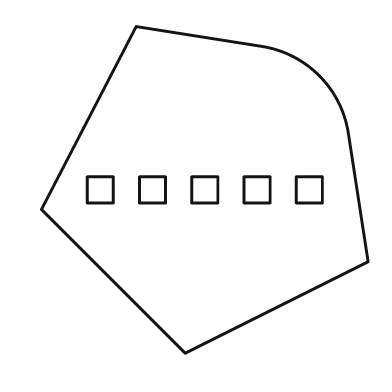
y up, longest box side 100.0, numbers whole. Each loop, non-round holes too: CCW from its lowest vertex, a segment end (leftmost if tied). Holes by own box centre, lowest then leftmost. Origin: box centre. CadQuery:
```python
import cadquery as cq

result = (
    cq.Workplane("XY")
    .moveTo(-6.0, -50.0)
    .lineTo(50.0, -22.0)
    .lineTo(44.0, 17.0)
    .threePointArc((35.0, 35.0), (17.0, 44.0))
    .lineTo(-21.0, 50.0)
    .lineTo(-50.0, -6.0)
    .close()
    .moveTo(-36.0, -4.0)
    .lineTo(-28.0, -4.0)
    .lineTo(-28.0, 4.0)
    .lineTo(-36.0, 4.0)
    .close()
    .moveTo(-20.0, -4.0)
    .lineTo(-12.0, -4.0)
    .lineTo(-12.0, 4.0)
    .lineTo(-20.0, 4.0)
    .close()
    .moveTo(-4.0, -4.0)
    .lineTo(4.0, -4.0)
    .lineTo(4.0, 4.0)
    .lineTo(-4.0, 4.0)
    .close()
    .moveTo(12.0, -4.0)
    .lineTo(20.0, -4.0)
    .lineTo(20.0, 4.0)
    .lineTo(12.0, 4.0)
    .close()
    .moveTo(28.0, -4.0)
    .lineTo(36.0, -4.0)
    .lineTo(36.0, 4.0)
    .lineTo(28.0, 4.0)
    .close()
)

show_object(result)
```